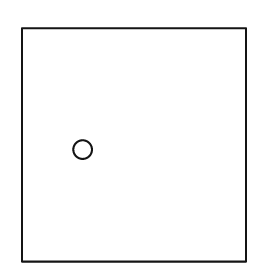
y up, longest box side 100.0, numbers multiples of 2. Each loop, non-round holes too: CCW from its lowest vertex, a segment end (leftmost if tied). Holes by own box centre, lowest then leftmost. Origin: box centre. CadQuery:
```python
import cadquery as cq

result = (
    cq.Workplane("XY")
    .moveTo(-48.0, -50.0)
    .lineTo(48.0, -50.0)
    .lineTo(48.0, 50.0)
    .lineTo(-48.0, 50.0)
    .close()
    .moveTo(-22.0, -2.0)
    .circle(4.0)
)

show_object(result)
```